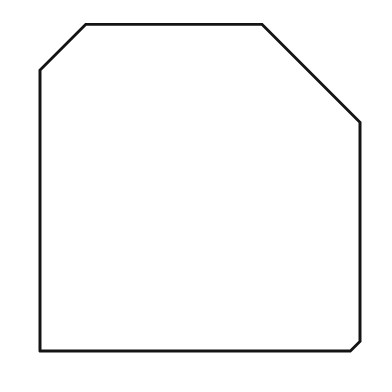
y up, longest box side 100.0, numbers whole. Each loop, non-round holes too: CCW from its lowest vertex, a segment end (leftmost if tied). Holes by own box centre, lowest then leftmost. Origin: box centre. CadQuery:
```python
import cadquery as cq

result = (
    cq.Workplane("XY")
    .moveTo(-49.0, -50.0)
    .lineTo(46.0, -50.0)
    .lineTo(49.0, -47.0)
    .lineTo(49.0, 20.0)
    .lineTo(19.0, 50.0)
    .lineTo(-35.0, 50.0)
    .lineTo(-49.0, 36.0)
    .close()
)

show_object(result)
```